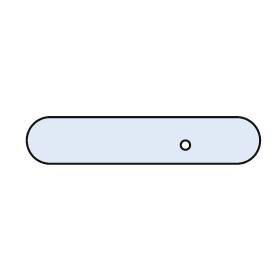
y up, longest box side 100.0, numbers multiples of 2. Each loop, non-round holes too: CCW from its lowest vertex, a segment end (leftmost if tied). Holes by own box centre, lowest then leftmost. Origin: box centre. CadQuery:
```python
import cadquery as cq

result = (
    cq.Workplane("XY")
    .moveTo(-40.0, -10.0)
    .lineTo(40.0, -10.0)
    .threePointArc((50.0, 0.0), (40.0, 10.0))
    .lineTo(-40.0, 10.0)
    .threePointArc((-50.0, 0.0), (-40.0, -10.0))
    .close()
    .moveTo(18.0, -2.0)
    .circle(2.0)
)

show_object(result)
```